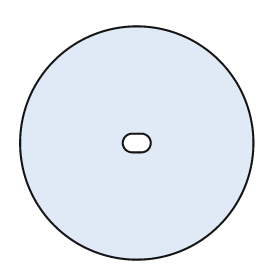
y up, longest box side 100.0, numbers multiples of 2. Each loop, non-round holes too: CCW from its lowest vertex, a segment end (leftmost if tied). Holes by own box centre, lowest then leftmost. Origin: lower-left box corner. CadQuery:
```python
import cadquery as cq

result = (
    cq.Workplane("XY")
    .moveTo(50.0, 50.0)
    .circle(50.0)
    .moveTo(48.0, 46.0)
    .lineTo(52.0, 46.0)
    .threePointArc((56.0, 50.0), (52.0, 54.0))
    .lineTo(48.0, 54.0)
    .threePointArc((44.0, 50.0), (48.0, 46.0))
    .close()
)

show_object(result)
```